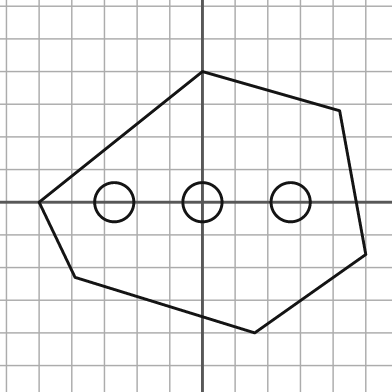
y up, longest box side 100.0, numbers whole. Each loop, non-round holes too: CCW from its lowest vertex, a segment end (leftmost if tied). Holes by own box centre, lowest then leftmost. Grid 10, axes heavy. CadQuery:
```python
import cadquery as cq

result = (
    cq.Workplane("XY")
    .moveTo(16.0, -40.0)
    .lineTo(50.0, -16.0)
    .lineTo(42.0, 28.0)
    .lineTo(0.0, 40.0)
    .lineTo(-50.0, 0.0)
    .lineTo(-39.0, -23.0)
    .close()
    .moveTo(-27.0, 0.0)
    .circle(6.0)
    .moveTo(0.0, 0.0)
    .circle(6.0)
    .moveTo(27.0, 0.0)
    .circle(6.0)
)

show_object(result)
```